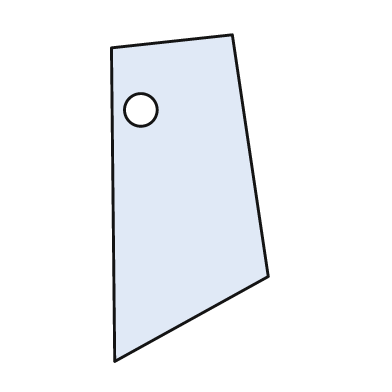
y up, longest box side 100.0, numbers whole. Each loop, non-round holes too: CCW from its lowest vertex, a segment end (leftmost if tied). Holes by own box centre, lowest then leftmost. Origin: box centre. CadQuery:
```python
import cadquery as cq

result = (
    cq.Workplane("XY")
    .moveTo(-23.0, -50.0)
    .lineTo(24.0, -24.0)
    .lineTo(13.0, 50.0)
    .lineTo(-24.0, 46.0)
    .close()
    .moveTo(-15.0, 27.0)
    .circle(5.0)
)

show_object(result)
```